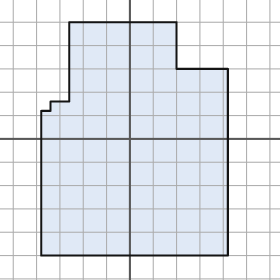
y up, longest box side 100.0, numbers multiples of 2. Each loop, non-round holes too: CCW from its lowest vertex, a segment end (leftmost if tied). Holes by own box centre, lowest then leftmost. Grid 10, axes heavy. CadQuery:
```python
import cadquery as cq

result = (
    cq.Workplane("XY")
    .moveTo(-38.0, -50.0)
    .lineTo(42.0, -50.0)
    .lineTo(42.0, 30.0)
    .lineTo(20.0, 30.0)
    .lineTo(20.0, 50.0)
    .lineTo(-26.0, 50.0)
    .lineTo(-26.0, 16.0)
    .lineTo(-34.0, 16.0)
    .lineTo(-34.0, 12.0)
    .lineTo(-38.0, 12.0)
    .close()
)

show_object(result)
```